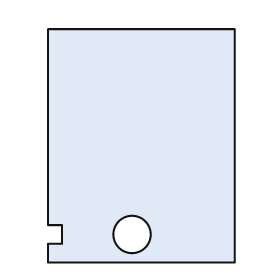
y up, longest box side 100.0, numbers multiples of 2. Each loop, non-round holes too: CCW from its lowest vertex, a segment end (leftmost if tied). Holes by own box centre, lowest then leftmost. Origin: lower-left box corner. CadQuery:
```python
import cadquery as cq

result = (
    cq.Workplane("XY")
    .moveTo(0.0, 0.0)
    .lineTo(80.0, 0.0)
    .lineTo(80.0, 100.0)
    .lineTo(0.0, 100.0)
    .lineTo(0.0, 16.0)
    .lineTo(6.0, 16.0)
    .lineTo(6.0, 8.0)
    .lineTo(0.0, 8.0)
    .close()
    .moveTo(36.0, 12.0)
    .circle(8.0)
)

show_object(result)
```